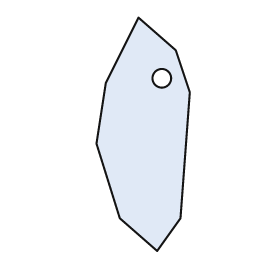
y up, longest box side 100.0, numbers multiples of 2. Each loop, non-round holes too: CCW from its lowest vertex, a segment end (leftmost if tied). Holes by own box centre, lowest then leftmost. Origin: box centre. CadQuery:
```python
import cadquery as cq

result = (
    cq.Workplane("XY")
    .moveTo(6.0, -50.0)
    .lineTo(16.0, -36.0)
    .lineTo(20.0, 18.0)
    .lineTo(14.0, 36.0)
    .lineTo(-2.0, 50.0)
    .lineTo(-16.0, 22.0)
    .lineTo(-20.0, -4.0)
    .lineTo(-10.0, -36.0)
    .close()
    .moveTo(8.0, 24.0)
    .circle(4.0)
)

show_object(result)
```